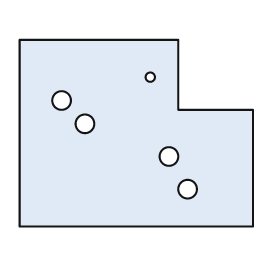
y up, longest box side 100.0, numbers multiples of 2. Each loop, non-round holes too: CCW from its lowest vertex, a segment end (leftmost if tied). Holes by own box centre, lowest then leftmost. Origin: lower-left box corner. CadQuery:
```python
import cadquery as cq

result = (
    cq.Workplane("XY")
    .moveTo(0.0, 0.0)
    .lineTo(100.0, 0.0)
    .lineTo(100.0, 50.0)
    .lineTo(68.0, 50.0)
    .lineTo(68.0, 80.0)
    .lineTo(0.0, 80.0)
    .close()
    .moveTo(72.0, 16.0)
    .circle(4.0)
    .moveTo(64.0, 30.0)
    .circle(4.0)
    .moveTo(28.0, 44.0)
    .circle(4.0)
    .moveTo(18.0, 54.0)
    .circle(4.0)
    .moveTo(56.0, 64.0)
    .circle(2.0)
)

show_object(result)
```